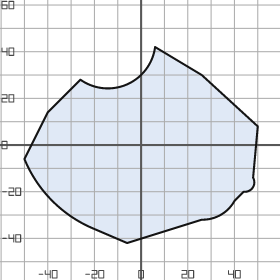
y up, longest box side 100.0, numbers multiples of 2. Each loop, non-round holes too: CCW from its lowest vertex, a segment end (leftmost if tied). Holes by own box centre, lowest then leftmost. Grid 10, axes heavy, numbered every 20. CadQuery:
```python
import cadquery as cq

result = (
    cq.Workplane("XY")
    .moveTo(-6.0, -42.0)
    .lineTo(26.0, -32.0)
    .threePointArc((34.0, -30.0), (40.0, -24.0))
    .lineTo(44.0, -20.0)
    .threePointArc((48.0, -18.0), (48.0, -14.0))
    .lineTo(50.0, 8.0)
    .lineTo(26.0, 30.0)
    .lineTo(6.0, 42.0)
    .threePointArc((-6.0, 26.0), (-26.0, 28.0))
    .lineTo(-40.0, 14.0)
    .lineTo(-50.0, -6.0)
    .threePointArc((-38.0, -24.0), (-20.0, -36.0))
    .close()
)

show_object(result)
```